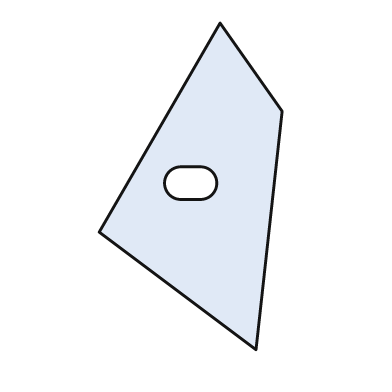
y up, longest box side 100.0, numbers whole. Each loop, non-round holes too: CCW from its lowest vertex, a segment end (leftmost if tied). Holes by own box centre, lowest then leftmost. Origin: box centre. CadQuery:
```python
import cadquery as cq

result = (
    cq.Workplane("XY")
    .moveTo(20.0, -50.0)
    .lineTo(28.0, 23.0)
    .lineTo(9.0, 50.0)
    .lineTo(-28.0, -14.0)
    .close()
    .moveTo(-3.0, -4.0)
    .lineTo(3.0, -4.0)
    .threePointArc((8.0, 1.0), (3.0, 6.0))
    .lineTo(-3.0, 6.0)
    .threePointArc((-8.0, 1.0), (-3.0, -4.0))
    .close()
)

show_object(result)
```